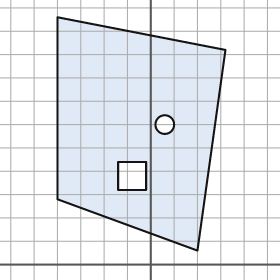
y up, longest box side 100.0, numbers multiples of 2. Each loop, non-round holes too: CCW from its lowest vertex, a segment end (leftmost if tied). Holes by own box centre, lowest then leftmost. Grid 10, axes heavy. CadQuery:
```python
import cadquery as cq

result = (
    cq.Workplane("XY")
    .moveTo(20.0, 6.0)
    .lineTo(32.0, 92.0)
    .lineTo(-40.0, 106.0)
    .lineTo(-40.0, 28.0)
    .close()
    .moveTo(-14.0, 32.0)
    .lineTo(-2.0, 32.0)
    .lineTo(-2.0, 44.0)
    .lineTo(-14.0, 44.0)
    .close()
    .moveTo(6.0, 60.0)
    .circle(4.0)
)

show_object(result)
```